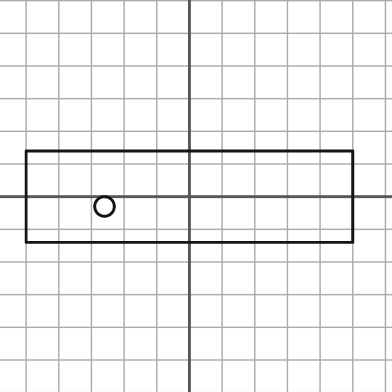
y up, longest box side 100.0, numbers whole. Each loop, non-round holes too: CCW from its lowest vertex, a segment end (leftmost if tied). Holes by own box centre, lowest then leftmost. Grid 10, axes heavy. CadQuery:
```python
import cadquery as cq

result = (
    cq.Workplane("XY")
    .moveTo(-50.0, -14.0)
    .lineTo(50.0, -14.0)
    .lineTo(50.0, 14.0)
    .lineTo(-50.0, 14.0)
    .close()
    .moveTo(-26.0, -3.0)
    .circle(3.0)
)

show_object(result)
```